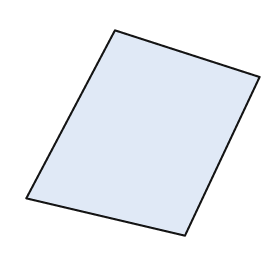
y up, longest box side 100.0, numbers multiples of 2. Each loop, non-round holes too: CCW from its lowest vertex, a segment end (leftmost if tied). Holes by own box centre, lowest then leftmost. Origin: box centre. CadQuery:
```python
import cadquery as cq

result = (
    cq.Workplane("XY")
    .moveTo(18.0, -44.0)
    .lineTo(50.0, 24.0)
    .lineTo(-12.0, 44.0)
    .lineTo(-50.0, -28.0)
    .close()
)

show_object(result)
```